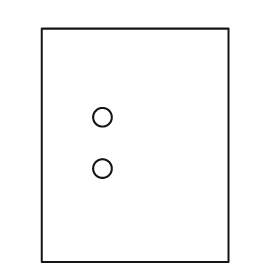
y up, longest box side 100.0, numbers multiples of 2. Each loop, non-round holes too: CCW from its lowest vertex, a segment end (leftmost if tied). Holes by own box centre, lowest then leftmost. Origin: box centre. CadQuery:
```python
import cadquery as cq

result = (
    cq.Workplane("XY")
    .moveTo(-40.0, -50.0)
    .lineTo(40.0, -50.0)
    .lineTo(40.0, 50.0)
    .lineTo(-40.0, 50.0)
    .close()
    .moveTo(-14.0, -10.0)
    .circle(4.0)
    .moveTo(-14.0, 12.0)
    .circle(4.0)
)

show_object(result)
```